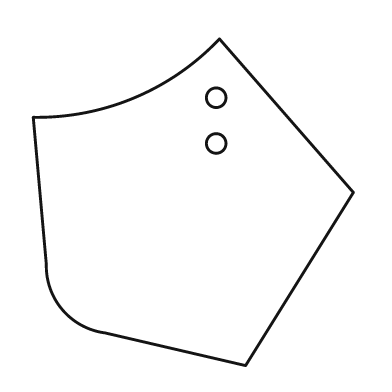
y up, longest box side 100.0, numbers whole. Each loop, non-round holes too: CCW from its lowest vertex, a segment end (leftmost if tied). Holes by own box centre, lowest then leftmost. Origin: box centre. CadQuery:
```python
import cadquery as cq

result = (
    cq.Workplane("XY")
    .moveTo(16.0, -50.0)
    .lineTo(49.0, 3.0)
    .lineTo(8.0, 50.0)
    .threePointArc((-18.0, 32.0), (-49.0, 26.0))
    .lineTo(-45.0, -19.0)
    .threePointArc((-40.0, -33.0), (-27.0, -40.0))
    .close()
    .moveTo(7.0, 18.0)
    .circle(3.0)
    .moveTo(7.0, 32.0)
    .circle(3.0)
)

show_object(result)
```